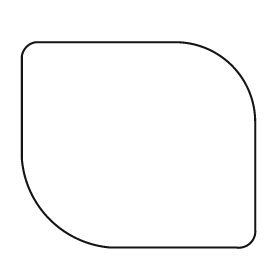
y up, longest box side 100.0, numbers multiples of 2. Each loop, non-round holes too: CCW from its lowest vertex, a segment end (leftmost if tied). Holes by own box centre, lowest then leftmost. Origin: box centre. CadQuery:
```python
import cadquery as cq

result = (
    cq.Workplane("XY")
    .moveTo(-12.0, -44.0)
    .lineTo(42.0, -44.0)
    .threePointArc((48.0, -42.0), (50.0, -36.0))
    .lineTo(50.0, 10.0)
    .threePointArc((40.0, 34.0), (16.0, 44.0))
    .lineTo(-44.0, 44.0)
    .threePointArc((-48.0, 42.0), (-50.0, 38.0))
    .lineTo(-50.0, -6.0)
    .threePointArc((-38.0, -32.0), (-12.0, -44.0))
    .close()
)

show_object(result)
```